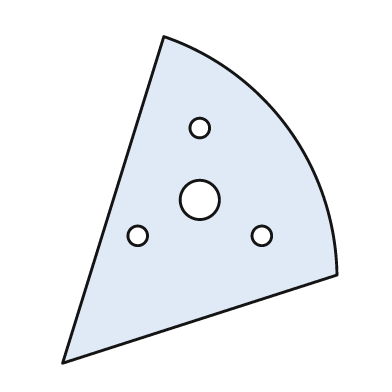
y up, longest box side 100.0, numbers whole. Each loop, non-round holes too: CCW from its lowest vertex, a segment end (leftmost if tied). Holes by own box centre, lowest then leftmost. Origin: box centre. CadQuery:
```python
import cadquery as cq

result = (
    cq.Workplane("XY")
    .moveTo(-42.0, -50.0)
    .lineTo(42.0, -23.0)
    .threePointArc((27.0, 22.0), (-11.0, 50.0))
    .close()
    .moveTo(-19.0, -11.0)
    .circle(3.0)
    .moveTo(19.0, -11.0)
    .circle(3.0)
    .moveTo(0.0, 0.0)
    .circle(6.0)
    .moveTo(0.0, 22.0)
    .circle(3.0)
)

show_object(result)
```